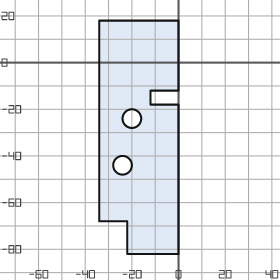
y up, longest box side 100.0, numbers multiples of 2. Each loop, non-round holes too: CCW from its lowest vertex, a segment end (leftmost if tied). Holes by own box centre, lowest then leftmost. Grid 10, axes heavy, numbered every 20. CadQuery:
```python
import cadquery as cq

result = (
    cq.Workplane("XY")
    .moveTo(-22.0, -82.0)
    .lineTo(0.0, -82.0)
    .lineTo(0.0, -18.0)
    .lineTo(-12.0, -18.0)
    .lineTo(-12.0, -12.0)
    .lineTo(0.0, -12.0)
    .lineTo(0.0, 18.0)
    .lineTo(-34.0, 18.0)
    .lineTo(-34.0, -68.0)
    .lineTo(-22.0, -68.0)
    .close()
    .moveTo(-24.0, -44.0)
    .circle(4.0)
    .moveTo(-20.0, -24.0)
    .circle(4.0)
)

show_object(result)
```